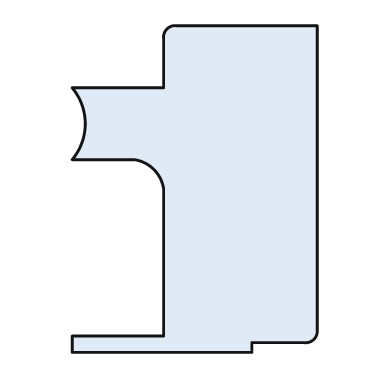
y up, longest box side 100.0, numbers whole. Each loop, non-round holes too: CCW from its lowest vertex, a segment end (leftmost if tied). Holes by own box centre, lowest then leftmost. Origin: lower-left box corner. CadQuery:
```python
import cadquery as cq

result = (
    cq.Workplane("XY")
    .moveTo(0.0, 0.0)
    .lineTo(55.0, 0.0)
    .lineTo(55.0, 3.0)
    .lineTo(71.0, 3.0)
    .threePointArc((74.0, 4.0), (75.0, 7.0))
    .lineTo(75.0, 100.0)
    .lineTo(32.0, 100.0)
    .threePointArc((29.0, 99.0), (28.0, 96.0))
    .lineTo(28.0, 81.0)
    .lineTo(0.0, 81.0)
    .threePointArc((4.0, 70.0), (0.0, 59.0))
    .lineTo(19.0, 59.0)
    .threePointArc((25.0, 56.0), (28.0, 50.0))
    .lineTo(28.0, 5.0)
    .lineTo(0.0, 5.0)
    .close()
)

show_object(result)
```